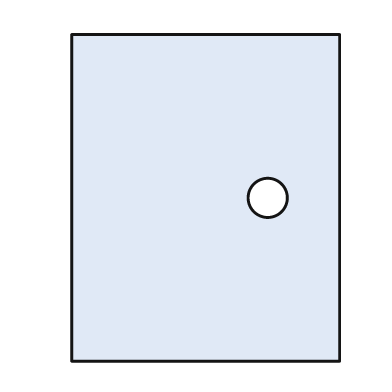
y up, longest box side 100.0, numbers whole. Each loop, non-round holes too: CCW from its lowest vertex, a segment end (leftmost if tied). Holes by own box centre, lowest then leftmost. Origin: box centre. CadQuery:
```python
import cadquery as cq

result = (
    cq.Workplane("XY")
    .moveTo(-41.0, -50.0)
    .lineTo(41.0, -50.0)
    .lineTo(41.0, 50.0)
    .lineTo(-41.0, 50.0)
    .close()
    .moveTo(19.0, 0.0)
    .circle(6.0)
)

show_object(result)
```